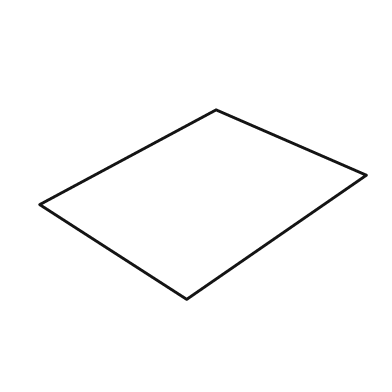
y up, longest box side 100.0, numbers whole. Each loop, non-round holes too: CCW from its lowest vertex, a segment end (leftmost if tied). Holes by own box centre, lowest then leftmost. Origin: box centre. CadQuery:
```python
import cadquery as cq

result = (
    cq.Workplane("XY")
    .moveTo(-5.0, -29.0)
    .lineTo(50.0, 9.0)
    .lineTo(4.0, 29.0)
    .lineTo(-50.0, 0.0)
    .close()
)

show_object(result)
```